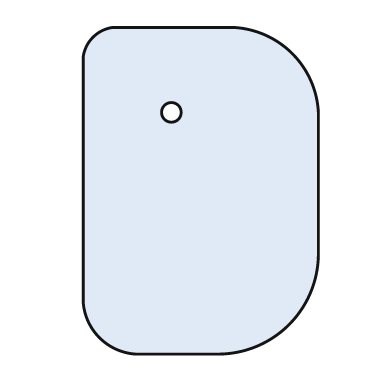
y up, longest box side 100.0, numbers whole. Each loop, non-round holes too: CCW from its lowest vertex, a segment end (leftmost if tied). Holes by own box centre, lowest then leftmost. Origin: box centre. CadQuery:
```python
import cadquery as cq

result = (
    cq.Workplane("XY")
    .moveTo(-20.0, -50.0)
    .lineTo(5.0, -50.0)
    .threePointArc((27.0, -41.0), (36.0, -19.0))
    .lineTo(36.0, 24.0)
    .threePointArc((28.0, 42.0), (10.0, 50.0))
    .lineTo(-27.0, 50.0)
    .threePointArc((-33.0, 47.0), (-36.0, 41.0))
    .lineTo(-36.0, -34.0)
    .threePointArc((-31.0, -45.0), (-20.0, -50.0))
    .close()
    .moveTo(-9.0, 24.0)
    .circle(3.0)
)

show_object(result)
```